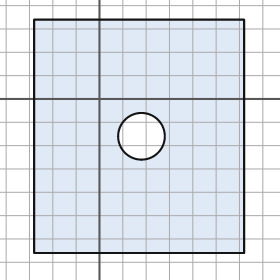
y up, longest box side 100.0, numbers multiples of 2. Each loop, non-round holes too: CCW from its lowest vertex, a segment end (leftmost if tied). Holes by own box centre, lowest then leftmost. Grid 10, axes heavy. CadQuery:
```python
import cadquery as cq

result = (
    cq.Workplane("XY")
    .moveTo(-28.0, -66.0)
    .lineTo(62.0, -66.0)
    .lineTo(62.0, 34.0)
    .lineTo(-28.0, 34.0)
    .close()
    .moveTo(18.0, -16.0)
    .circle(10.0)
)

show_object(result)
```